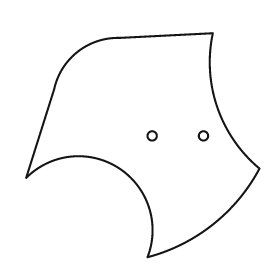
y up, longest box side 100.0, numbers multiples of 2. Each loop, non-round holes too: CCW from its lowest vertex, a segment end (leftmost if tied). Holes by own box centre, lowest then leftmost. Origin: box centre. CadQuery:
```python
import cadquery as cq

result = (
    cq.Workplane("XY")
    .moveTo(2.0, -48.0)
    .threePointArc((30.0, -34.0), (50.0, -10.0))
    .threePointArc((32.0, 16.0), (30.0, 48.0))
    .lineTo(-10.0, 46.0)
    .threePointArc((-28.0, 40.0), (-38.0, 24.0))
    .lineTo(-50.0, -14.0)
    .threePointArc((-10.0, -10.0), (2.0, -48.0))
    .close()
    .moveTo(4.0, 4.0)
    .circle(2.0)
    .moveTo(26.0, 4.0)
    .circle(2.0)
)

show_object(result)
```